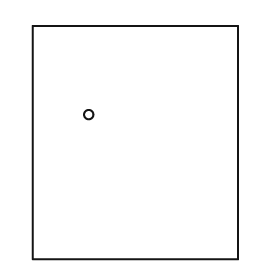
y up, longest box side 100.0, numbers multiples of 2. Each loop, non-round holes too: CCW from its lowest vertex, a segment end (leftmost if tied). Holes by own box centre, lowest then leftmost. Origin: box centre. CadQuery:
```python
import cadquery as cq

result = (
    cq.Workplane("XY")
    .moveTo(-44.0, -50.0)
    .lineTo(44.0, -50.0)
    .lineTo(44.0, 50.0)
    .lineTo(-44.0, 50.0)
    .close()
    .moveTo(-20.0, 12.0)
    .circle(2.0)
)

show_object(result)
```